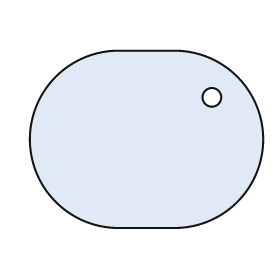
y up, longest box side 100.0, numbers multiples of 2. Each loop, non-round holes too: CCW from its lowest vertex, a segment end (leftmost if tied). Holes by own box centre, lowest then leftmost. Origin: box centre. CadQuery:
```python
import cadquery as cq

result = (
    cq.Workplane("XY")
    .moveTo(-12.0, -38.0)
    .lineTo(12.0, -38.0)
    .threePointArc((50.0, 0.0), (12.0, 38.0))
    .lineTo(-12.0, 38.0)
    .threePointArc((-50.0, 0.0), (-12.0, -38.0))
    .close()
    .moveTo(28.0, 18.0)
    .circle(4.0)
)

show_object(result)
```